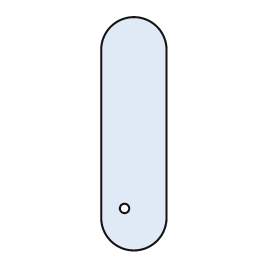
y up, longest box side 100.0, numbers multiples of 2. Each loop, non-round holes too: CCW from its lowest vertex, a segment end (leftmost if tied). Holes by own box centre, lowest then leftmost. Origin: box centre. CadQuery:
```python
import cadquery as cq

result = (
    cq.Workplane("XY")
    .moveTo(-14.0, -36.0)
    .threePointArc((0.0, -50.0), (14.0, -36.0))
    .lineTo(14.0, 36.0)
    .threePointArc((0.0, 50.0), (-14.0, 36.0))
    .close()
    .moveTo(-4.0, -32.0)
    .circle(2.0)
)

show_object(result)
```